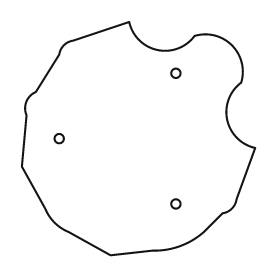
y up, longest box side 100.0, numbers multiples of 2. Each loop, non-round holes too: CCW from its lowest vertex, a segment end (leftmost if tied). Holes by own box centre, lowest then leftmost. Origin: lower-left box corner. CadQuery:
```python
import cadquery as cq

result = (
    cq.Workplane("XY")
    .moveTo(38.0, 0.0)
    .lineTo(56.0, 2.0)
    .threePointArc((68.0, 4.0), (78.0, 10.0))
    .lineTo(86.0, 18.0)
    .threePointArc((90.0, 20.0), (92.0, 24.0))
    .lineTo(100.0, 46.0)
    .threePointArc((88.0, 58.0), (94.0, 74.0))
    .threePointArc((90.0, 90.0), (74.0, 94.0))
    .threePointArc((58.0, 88.0), (46.0, 100.0))
    .lineTo(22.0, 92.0)
    .threePointArc((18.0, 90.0), (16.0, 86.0))
    .lineTo(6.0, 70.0)
    .threePointArc((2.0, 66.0), (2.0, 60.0))
    .lineTo(0.0, 38.0)
    .lineTo(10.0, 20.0)
    .threePointArc((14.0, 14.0), (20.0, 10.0))
    .close()
    .moveTo(66.0, 22.0)
    .circle(2.0)
    .moveTo(16.0, 50.0)
    .circle(2.0)
    .moveTo(66.0, 78.0)
    .circle(2.0)
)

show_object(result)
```